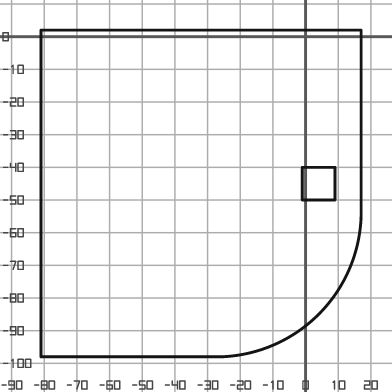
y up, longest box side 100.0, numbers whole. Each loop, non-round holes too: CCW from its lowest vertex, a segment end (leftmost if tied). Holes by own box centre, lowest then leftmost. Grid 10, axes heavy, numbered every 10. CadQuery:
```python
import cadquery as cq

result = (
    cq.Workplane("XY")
    .moveTo(-81.0, -98.0)
    .lineTo(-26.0, -98.0)
    .threePointArc((4.0, -85.0), (17.0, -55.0))
    .lineTo(17.0, 2.0)
    .lineTo(-81.0, 2.0)
    .close()
    .moveTo(-1.0, -50.0)
    .lineTo(9.0, -50.0)
    .lineTo(9.0, -40.0)
    .lineTo(-1.0, -40.0)
    .close()
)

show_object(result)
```